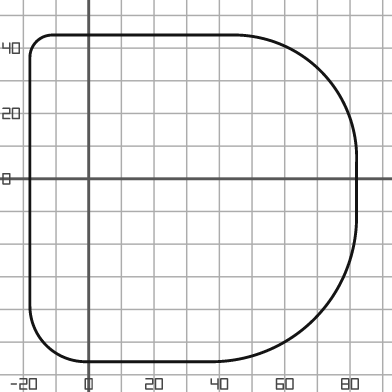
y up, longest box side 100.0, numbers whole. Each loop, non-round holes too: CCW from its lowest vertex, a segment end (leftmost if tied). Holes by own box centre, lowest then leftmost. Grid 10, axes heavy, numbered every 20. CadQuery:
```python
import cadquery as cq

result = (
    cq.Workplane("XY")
    .moveTo(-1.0, -56.0)
    .lineTo(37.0, -56.0)
    .threePointArc((69.0, -43.0), (82.0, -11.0))
    .lineTo(82.0, 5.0)
    .threePointArc((71.0, 33.0), (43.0, 44.0))
    .lineTo(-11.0, 44.0)
    .threePointArc((-16.0, 42.0), (-18.0, 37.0))
    .lineTo(-18.0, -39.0)
    .threePointArc((-13.0, -51.0), (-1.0, -56.0))
    .close()
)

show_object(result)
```